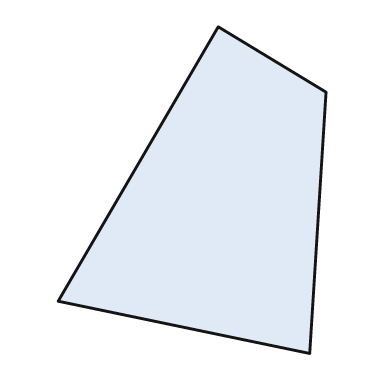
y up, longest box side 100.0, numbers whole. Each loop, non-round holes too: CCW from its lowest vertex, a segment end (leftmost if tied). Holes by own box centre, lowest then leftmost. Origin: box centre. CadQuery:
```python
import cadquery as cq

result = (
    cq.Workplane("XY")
    .moveTo(36.0, -50.0)
    .lineTo(41.0, 30.0)
    .lineTo(8.0, 50.0)
    .lineTo(-41.0, -34.0)
    .close()
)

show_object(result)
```